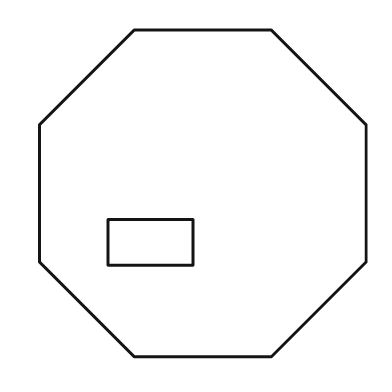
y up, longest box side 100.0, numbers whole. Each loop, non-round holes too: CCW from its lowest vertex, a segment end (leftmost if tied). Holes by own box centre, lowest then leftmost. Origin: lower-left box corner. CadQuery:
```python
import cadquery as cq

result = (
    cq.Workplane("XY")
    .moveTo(29.0, 0.0)
    .lineTo(71.0, 0.0)
    .lineTo(100.0, 29.0)
    .lineTo(100.0, 71.0)
    .lineTo(71.0, 100.0)
    .lineTo(29.0, 100.0)
    .lineTo(0.0, 71.0)
    .lineTo(0.0, 29.0)
    .close()
    .moveTo(21.0, 28.0)
    .lineTo(47.0, 28.0)
    .lineTo(47.0, 42.0)
    .lineTo(21.0, 42.0)
    .close()
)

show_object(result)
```